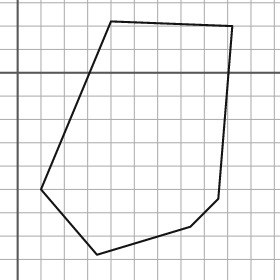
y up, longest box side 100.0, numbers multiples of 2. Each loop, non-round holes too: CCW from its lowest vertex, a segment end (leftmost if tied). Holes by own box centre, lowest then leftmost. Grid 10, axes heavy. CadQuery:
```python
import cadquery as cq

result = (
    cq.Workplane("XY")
    .moveTo(34.0, -78.0)
    .lineTo(74.0, -66.0)
    .lineTo(86.0, -54.0)
    .lineTo(92.0, 20.0)
    .lineTo(40.0, 22.0)
    .lineTo(10.0, -50.0)
    .close()
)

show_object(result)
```